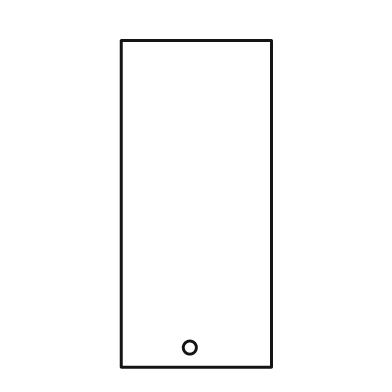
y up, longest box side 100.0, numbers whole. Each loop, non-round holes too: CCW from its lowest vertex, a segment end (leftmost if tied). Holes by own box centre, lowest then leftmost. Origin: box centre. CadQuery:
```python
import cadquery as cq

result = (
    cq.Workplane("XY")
    .moveTo(-23.0, -50.0)
    .lineTo(23.0, -50.0)
    .lineTo(23.0, 50.0)
    .lineTo(-23.0, 50.0)
    .close()
    .moveTo(-2.0, -44.0)
    .circle(2.0)
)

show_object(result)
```